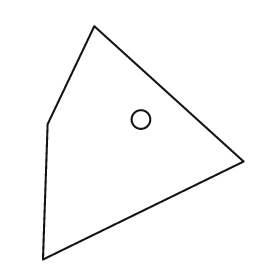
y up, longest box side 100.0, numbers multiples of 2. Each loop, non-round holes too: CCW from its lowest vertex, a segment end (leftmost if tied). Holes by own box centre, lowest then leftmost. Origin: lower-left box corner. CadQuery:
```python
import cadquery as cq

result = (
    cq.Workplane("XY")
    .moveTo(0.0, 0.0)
    .lineTo(86.0, 42.0)
    .lineTo(22.0, 100.0)
    .lineTo(2.0, 58.0)
    .close()
    .moveTo(42.0, 60.0)
    .circle(4.0)
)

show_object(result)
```